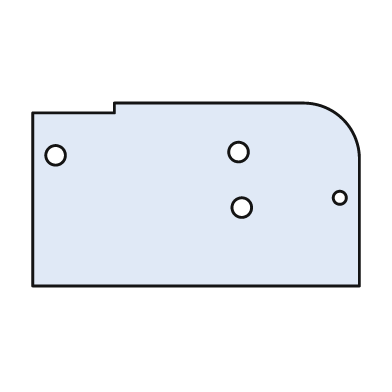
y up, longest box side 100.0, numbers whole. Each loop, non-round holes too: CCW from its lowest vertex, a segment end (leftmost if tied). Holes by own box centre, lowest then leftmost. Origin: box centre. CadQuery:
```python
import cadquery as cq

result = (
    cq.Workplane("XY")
    .moveTo(-50.0, -28.0)
    .lineTo(50.0, -28.0)
    .lineTo(50.0, 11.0)
    .threePointArc((45.0, 23.0), (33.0, 28.0))
    .lineTo(-25.0, 28.0)
    .lineTo(-25.0, 25.0)
    .lineTo(-50.0, 25.0)
    .close()
    .moveTo(14.0, -4.0)
    .circle(3.0)
    .moveTo(44.0, -1.0)
    .circle(2.0)
    .moveTo(-43.0, 12.0)
    .circle(3.0)
    .moveTo(13.0, 13.0)
    .circle(3.0)
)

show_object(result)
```